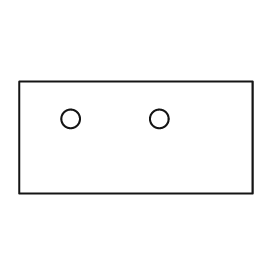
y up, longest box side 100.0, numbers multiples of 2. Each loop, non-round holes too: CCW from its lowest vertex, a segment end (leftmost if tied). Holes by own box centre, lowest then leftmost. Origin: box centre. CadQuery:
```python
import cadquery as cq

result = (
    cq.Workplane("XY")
    .moveTo(-50.0, -24.0)
    .lineTo(50.0, -24.0)
    .lineTo(50.0, 24.0)
    .lineTo(-50.0, 24.0)
    .close()
    .moveTo(-28.0, 8.0)
    .circle(4.0)
    .moveTo(10.0, 8.0)
    .circle(4.0)
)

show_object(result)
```